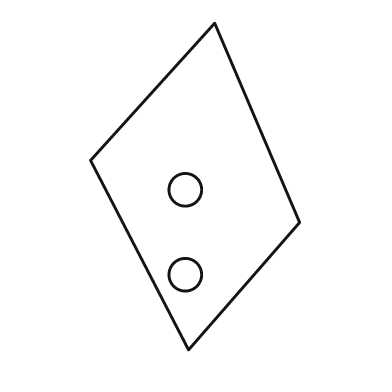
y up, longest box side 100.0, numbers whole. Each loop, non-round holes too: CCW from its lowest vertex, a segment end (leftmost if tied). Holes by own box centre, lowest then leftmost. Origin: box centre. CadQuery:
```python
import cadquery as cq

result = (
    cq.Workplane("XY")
    .moveTo(-2.0, -50.0)
    .lineTo(32.0, -11.0)
    .lineTo(6.0, 50.0)
    .lineTo(-32.0, 8.0)
    .close()
    .moveTo(-3.0, -27.0)
    .circle(5.0)
    .moveTo(-3.0, -1.0)
    .circle(5.0)
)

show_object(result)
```